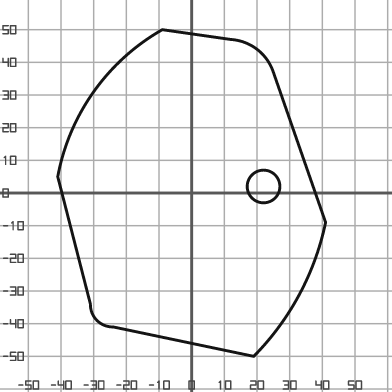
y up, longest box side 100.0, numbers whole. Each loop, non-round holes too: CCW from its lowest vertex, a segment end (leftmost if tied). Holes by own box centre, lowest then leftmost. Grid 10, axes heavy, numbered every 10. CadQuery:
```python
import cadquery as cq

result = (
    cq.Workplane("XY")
    .moveTo(19.0, -50.0)
    .threePointArc((33.0, -31.0), (41.0, -9.0))
    .lineTo(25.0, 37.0)
    .threePointArc((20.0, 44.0), (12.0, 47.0))
    .lineTo(-9.0, 50.0)
    .threePointArc((-30.0, 31.0), (-41.0, 5.0))
    .lineTo(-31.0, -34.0)
    .threePointArc((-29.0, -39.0), (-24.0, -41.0))
    .close()
    .moveTo(22.0, 2.0)
    .circle(5.0)
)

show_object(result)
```